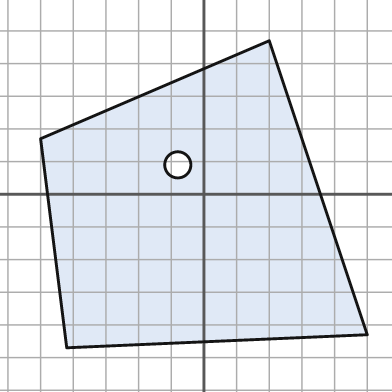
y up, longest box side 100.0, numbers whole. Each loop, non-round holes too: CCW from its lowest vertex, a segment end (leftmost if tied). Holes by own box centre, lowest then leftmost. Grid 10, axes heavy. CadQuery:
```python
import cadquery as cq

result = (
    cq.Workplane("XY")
    .moveTo(-42.0, -47.0)
    .lineTo(50.0, -43.0)
    .lineTo(20.0, 47.0)
    .lineTo(-50.0, 17.0)
    .close()
    .moveTo(-8.0, 9.0)
    .circle(4.0)
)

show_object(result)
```